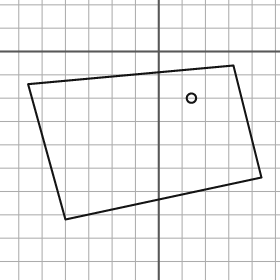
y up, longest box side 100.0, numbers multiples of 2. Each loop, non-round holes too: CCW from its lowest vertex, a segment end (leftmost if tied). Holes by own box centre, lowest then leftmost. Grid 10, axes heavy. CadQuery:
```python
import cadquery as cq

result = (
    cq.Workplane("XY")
    .moveTo(-40.0, -72.0)
    .lineTo(44.0, -54.0)
    .lineTo(32.0, -6.0)
    .lineTo(-56.0, -14.0)
    .close()
    .moveTo(14.0, -20.0)
    .circle(2.0)
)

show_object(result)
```